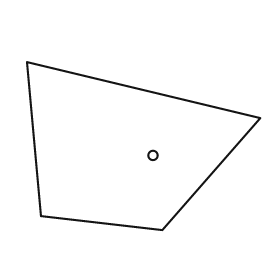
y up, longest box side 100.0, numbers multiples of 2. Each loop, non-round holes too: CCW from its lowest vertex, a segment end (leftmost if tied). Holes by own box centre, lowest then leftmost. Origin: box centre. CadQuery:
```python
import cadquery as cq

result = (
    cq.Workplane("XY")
    .moveTo(8.0, -36.0)
    .lineTo(50.0, 12.0)
    .lineTo(-50.0, 36.0)
    .lineTo(-44.0, -30.0)
    .close()
    .moveTo(4.0, -4.0)
    .circle(2.0)
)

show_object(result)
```